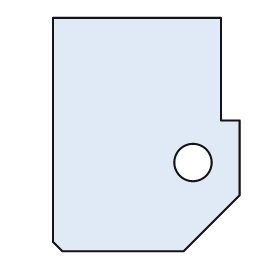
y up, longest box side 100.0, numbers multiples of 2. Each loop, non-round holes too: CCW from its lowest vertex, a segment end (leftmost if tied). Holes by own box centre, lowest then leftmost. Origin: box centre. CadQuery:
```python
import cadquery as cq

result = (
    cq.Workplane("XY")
    .moveTo(-36.0, -50.0)
    .lineTo(16.0, -50.0)
    .lineTo(40.0, -26.0)
    .lineTo(40.0, 6.0)
    .lineTo(32.0, 6.0)
    .lineTo(32.0, 50.0)
    .lineTo(-40.0, 50.0)
    .lineTo(-40.0, -46.0)
    .close()
    .moveTo(20.0, -12.0)
    .circle(8.0)
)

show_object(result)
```